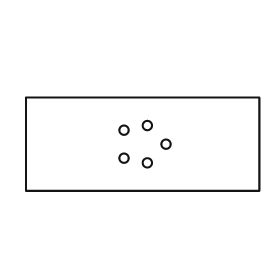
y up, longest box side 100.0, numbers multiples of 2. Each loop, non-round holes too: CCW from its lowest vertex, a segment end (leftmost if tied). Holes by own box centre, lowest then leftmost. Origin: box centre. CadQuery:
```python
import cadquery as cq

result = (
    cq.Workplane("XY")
    .moveTo(-50.0, -20.0)
    .lineTo(50.0, -20.0)
    .lineTo(50.0, 20.0)
    .lineTo(-50.0, 20.0)
    .close()
    .moveTo(2.0, -8.0)
    .circle(2.0)
    .moveTo(-8.0, -6.0)
    .circle(2.0)
    .moveTo(10.0, 0.0)
    .circle(2.0)
    .moveTo(-8.0, 6.0)
    .circle(2.0)
    .moveTo(2.0, 8.0)
    .circle(2.0)
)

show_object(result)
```